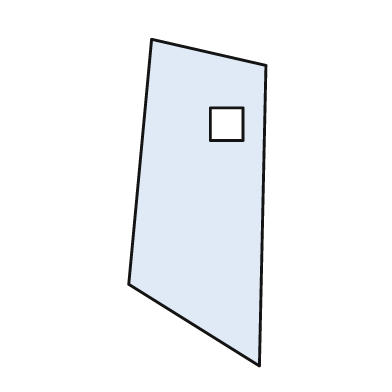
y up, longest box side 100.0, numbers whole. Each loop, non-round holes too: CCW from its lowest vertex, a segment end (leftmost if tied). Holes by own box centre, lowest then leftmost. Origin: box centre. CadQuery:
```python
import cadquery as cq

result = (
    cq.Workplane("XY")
    .moveTo(19.0, -50.0)
    .lineTo(21.0, 42.0)
    .lineTo(-14.0, 50.0)
    .lineTo(-21.0, -25.0)
    .close()
    .moveTo(4.0, 19.0)
    .lineTo(14.0, 19.0)
    .lineTo(14.0, 29.0)
    .lineTo(4.0, 29.0)
    .close()
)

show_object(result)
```